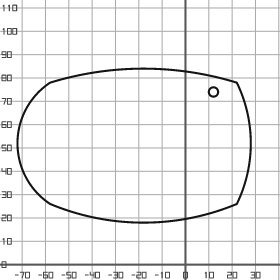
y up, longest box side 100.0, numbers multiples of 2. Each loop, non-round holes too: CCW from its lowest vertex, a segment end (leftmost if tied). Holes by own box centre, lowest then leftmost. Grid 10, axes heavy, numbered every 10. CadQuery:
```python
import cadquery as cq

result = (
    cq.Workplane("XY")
    .moveTo(-58.0, 26.0)
    .threePointArc((-18.0, 18.0), (22.0, 26.0))
    .threePointArc((28.0, 52.0), (22.0, 78.0))
    .threePointArc((-18.0, 84.0), (-58.0, 78.0))
    .threePointArc((-72.0, 52.0), (-58.0, 26.0))
    .close()
    .moveTo(12.0, 74.0)
    .circle(2.0)
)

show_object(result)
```